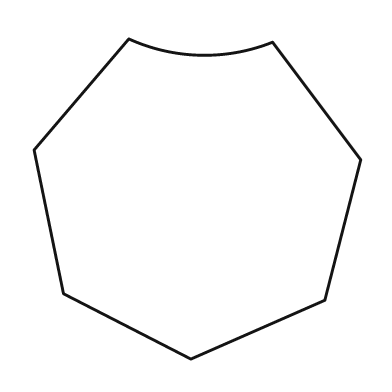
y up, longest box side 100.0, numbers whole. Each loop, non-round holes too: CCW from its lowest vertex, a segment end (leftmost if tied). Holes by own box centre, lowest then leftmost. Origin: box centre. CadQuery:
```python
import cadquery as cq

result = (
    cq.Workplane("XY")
    .moveTo(-2.0, -49.0)
    .lineTo(39.0, -31.0)
    .lineTo(50.0, 12.0)
    .lineTo(23.0, 48.0)
    .threePointArc((1.0, 44.0), (-21.0, 49.0))
    .lineTo(-50.0, 15.0)
    .lineTo(-41.0, -29.0)
    .close()
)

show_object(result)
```